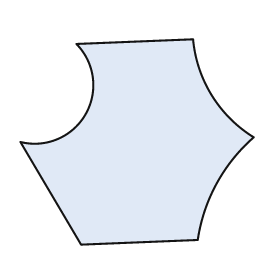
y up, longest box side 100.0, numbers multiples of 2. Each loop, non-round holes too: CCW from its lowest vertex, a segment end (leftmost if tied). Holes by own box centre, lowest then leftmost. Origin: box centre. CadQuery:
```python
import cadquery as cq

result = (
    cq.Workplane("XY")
    .moveTo(-24.0, -44.0)
    .lineTo(26.0, -42.0)
    .threePointArc((34.0, -18.0), (50.0, 2.0))
    .threePointArc((32.0, 20.0), (24.0, 44.0))
    .lineTo(-26.0, 42.0)
    .threePointArc((-22.0, 12.0), (-50.0, 0.0))
    .close()
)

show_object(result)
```